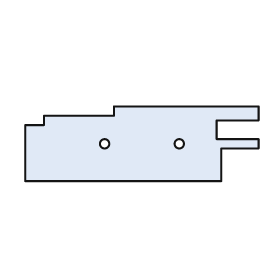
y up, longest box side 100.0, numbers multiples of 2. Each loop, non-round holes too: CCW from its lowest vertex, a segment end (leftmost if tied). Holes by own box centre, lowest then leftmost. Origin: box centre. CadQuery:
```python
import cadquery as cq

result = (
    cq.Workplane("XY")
    .moveTo(-50.0, -16.0)
    .lineTo(34.0, -16.0)
    .lineTo(34.0, -2.0)
    .lineTo(50.0, -2.0)
    .lineTo(50.0, 2.0)
    .lineTo(32.0, 2.0)
    .lineTo(32.0, 10.0)
    .lineTo(50.0, 10.0)
    .lineTo(50.0, 16.0)
    .lineTo(-12.0, 16.0)
    .lineTo(-12.0, 12.0)
    .lineTo(-42.0, 12.0)
    .lineTo(-42.0, 8.0)
    .lineTo(-50.0, 8.0)
    .close()
    .moveTo(-16.0, 0.0)
    .circle(2.0)
    .moveTo(16.0, 0.0)
    .circle(2.0)
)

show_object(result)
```